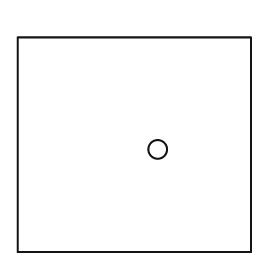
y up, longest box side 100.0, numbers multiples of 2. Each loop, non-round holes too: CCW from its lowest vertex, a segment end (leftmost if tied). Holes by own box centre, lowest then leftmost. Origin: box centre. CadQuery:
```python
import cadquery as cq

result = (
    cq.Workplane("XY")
    .moveTo(-50.0, -46.0)
    .lineTo(50.0, -46.0)
    .lineTo(50.0, 46.0)
    .lineTo(-50.0, 46.0)
    .close()
    .moveTo(10.0, -2.0)
    .circle(4.0)
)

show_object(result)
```